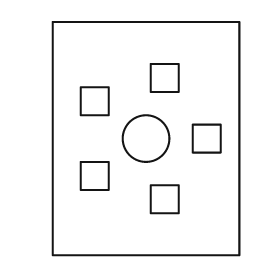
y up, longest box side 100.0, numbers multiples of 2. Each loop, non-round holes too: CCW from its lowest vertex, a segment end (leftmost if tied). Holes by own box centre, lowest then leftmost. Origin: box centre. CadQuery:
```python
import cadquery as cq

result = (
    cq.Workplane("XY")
    .moveTo(-40.0, -50.0)
    .lineTo(40.0, -50.0)
    .lineTo(40.0, 50.0)
    .lineTo(-40.0, 50.0)
    .close()
    .moveTo(2.0, -32.0)
    .lineTo(14.0, -32.0)
    .lineTo(14.0, -20.0)
    .lineTo(2.0, -20.0)
    .close()
    .moveTo(-28.0, -22.0)
    .lineTo(-16.0, -22.0)
    .lineTo(-16.0, -10.0)
    .lineTo(-28.0, -10.0)
    .close()
    .moveTo(0.0, 0.0)
    .circle(10.0)
    .moveTo(20.0, -6.0)
    .lineTo(32.0, -6.0)
    .lineTo(32.0, 6.0)
    .lineTo(20.0, 6.0)
    .close()
    .moveTo(-28.0, 10.0)
    .lineTo(-16.0, 10.0)
    .lineTo(-16.0, 22.0)
    .lineTo(-28.0, 22.0)
    .close()
    .moveTo(2.0, 20.0)
    .lineTo(14.0, 20.0)
    .lineTo(14.0, 32.0)
    .lineTo(2.0, 32.0)
    .close()
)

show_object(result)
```